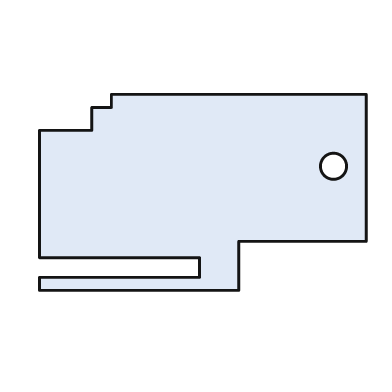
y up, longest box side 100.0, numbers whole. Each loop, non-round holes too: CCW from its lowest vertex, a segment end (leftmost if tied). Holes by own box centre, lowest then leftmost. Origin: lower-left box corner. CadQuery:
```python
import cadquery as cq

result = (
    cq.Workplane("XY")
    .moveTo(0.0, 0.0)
    .lineTo(61.0, 0.0)
    .lineTo(61.0, 15.0)
    .lineTo(100.0, 15.0)
    .lineTo(100.0, 60.0)
    .lineTo(22.0, 60.0)
    .lineTo(22.0, 56.0)
    .lineTo(16.0, 56.0)
    .lineTo(16.0, 49.0)
    .lineTo(0.0, 49.0)
    .lineTo(0.0, 10.0)
    .lineTo(49.0, 10.0)
    .lineTo(49.0, 4.0)
    .lineTo(0.0, 4.0)
    .close()
    .moveTo(90.0, 38.0)
    .circle(4.0)
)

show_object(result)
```